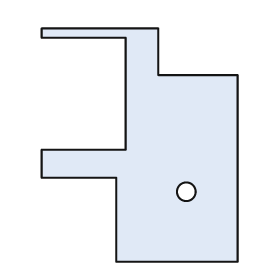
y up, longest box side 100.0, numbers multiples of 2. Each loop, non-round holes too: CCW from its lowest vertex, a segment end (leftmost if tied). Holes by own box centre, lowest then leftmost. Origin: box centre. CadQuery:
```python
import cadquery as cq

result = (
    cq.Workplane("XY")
    .moveTo(-10.0, -50.0)
    .lineTo(42.0, -50.0)
    .lineTo(42.0, 30.0)
    .lineTo(8.0, 30.0)
    .lineTo(8.0, 50.0)
    .lineTo(-42.0, 50.0)
    .lineTo(-42.0, 46.0)
    .lineTo(-6.0, 46.0)
    .lineTo(-6.0, -2.0)
    .lineTo(-42.0, -2.0)
    .lineTo(-42.0, -14.0)
    .lineTo(-10.0, -14.0)
    .close()
    .moveTo(20.0, -20.0)
    .circle(4.0)
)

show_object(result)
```